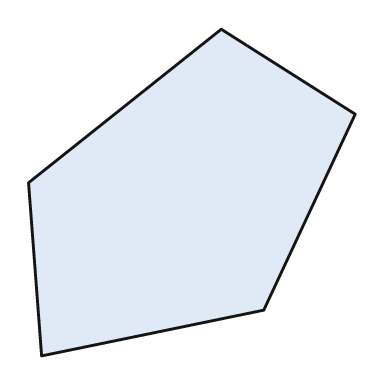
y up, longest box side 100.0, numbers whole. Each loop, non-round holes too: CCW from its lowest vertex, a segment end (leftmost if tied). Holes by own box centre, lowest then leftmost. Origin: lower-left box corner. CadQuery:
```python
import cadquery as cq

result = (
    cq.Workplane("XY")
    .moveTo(4.0, 0.0)
    .lineTo(72.0, 14.0)
    .lineTo(100.0, 74.0)
    .lineTo(59.0, 100.0)
    .lineTo(0.0, 53.0)
    .close()
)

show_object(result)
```